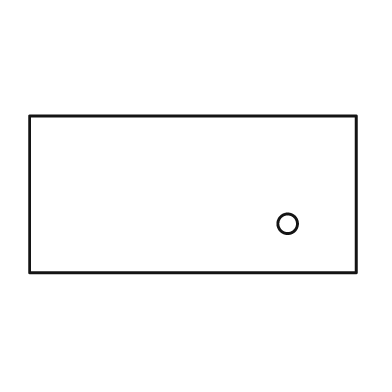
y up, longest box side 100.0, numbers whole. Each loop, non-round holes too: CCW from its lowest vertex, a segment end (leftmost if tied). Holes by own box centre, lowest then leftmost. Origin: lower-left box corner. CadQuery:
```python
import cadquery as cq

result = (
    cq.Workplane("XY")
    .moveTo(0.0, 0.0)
    .lineTo(100.0, 0.0)
    .lineTo(100.0, 48.0)
    .lineTo(0.0, 48.0)
    .close()
    .moveTo(79.0, 15.0)
    .circle(3.0)
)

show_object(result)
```